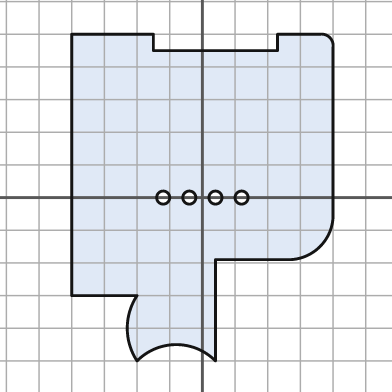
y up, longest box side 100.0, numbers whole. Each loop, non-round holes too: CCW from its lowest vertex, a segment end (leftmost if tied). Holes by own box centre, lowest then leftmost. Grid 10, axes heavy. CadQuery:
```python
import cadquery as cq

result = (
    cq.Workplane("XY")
    .moveTo(-20.0, -50.0)
    .threePointArc((-8.0, -45.0), (4.0, -50.0))
    .lineTo(4.0, -19.0)
    .lineTo(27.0, -19.0)
    .threePointArc((36.0, -15.0), (40.0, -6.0))
    .lineTo(40.0, 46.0)
    .threePointArc((39.0, 49.0), (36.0, 50.0))
    .lineTo(23.0, 50.0)
    .lineTo(23.0, 45.0)
    .lineTo(-15.0, 45.0)
    .lineTo(-15.0, 50.0)
    .lineTo(-40.0, 50.0)
    .lineTo(-40.0, -30.0)
    .lineTo(-20.0, -30.0)
    .threePointArc((-23.0, -40.0), (-20.0, -50.0))
    .close()
    .moveTo(-12.0, 0.0)
    .circle(2.0)
    .moveTo(-4.0, 0.0)
    .circle(2.0)
    .moveTo(4.0, 0.0)
    .circle(2.0)
    .moveTo(12.0, 0.0)
    .circle(2.0)
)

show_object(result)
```